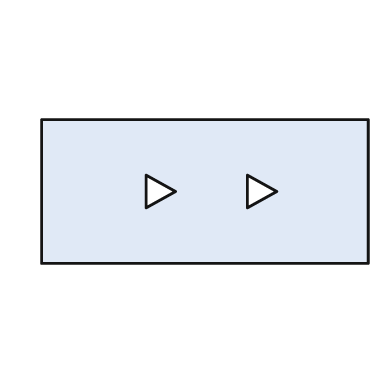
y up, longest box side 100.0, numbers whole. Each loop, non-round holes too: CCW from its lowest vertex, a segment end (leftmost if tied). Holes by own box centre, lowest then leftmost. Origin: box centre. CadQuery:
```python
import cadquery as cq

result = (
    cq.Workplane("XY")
    .moveTo(-50.0, -22.0)
    .lineTo(50.0, -22.0)
    .lineTo(50.0, 22.0)
    .lineTo(-50.0, 22.0)
    .close()
    .moveTo(-18.0, -5.0)
    .lineTo(-9.0, 0.0)
    .lineTo(-18.0, 5.0)
    .close()
    .moveTo(13.0, -5.0)
    .lineTo(22.0, 0.0)
    .lineTo(13.0, 5.0)
    .close()
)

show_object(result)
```